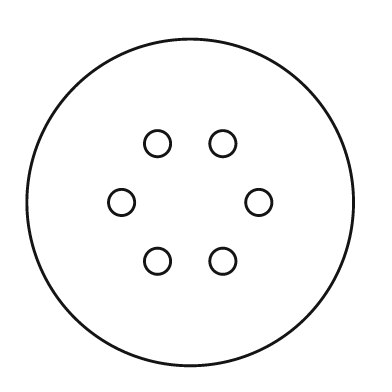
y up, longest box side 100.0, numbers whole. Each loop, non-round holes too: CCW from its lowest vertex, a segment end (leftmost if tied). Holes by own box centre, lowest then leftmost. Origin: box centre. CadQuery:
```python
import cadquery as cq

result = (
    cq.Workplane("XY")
    .moveTo(0.0, 0.0)
    .circle(50.0)
    .moveTo(-10.0, -18.0)
    .circle(4.0)
    .moveTo(10.0, -18.0)
    .circle(4.0)
    .moveTo(-21.0, 0.0)
    .circle(4.0)
    .moveTo(21.0, 0.0)
    .circle(4.0)
    .moveTo(-10.0, 18.0)
    .circle(4.0)
    .moveTo(10.0, 18.0)
    .circle(4.0)
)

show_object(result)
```